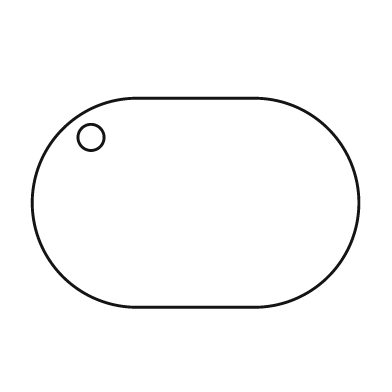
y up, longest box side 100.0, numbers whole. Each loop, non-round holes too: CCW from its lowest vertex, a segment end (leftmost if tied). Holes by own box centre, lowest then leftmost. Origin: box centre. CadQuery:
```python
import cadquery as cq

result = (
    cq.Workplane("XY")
    .moveTo(-18.0, -32.0)
    .lineTo(18.0, -32.0)
    .threePointArc((50.0, 0.0), (18.0, 32.0))
    .lineTo(-18.0, 32.0)
    .threePointArc((-50.0, 0.0), (-18.0, -32.0))
    .close()
    .moveTo(-32.0, 20.0)
    .circle(4.0)
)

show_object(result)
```